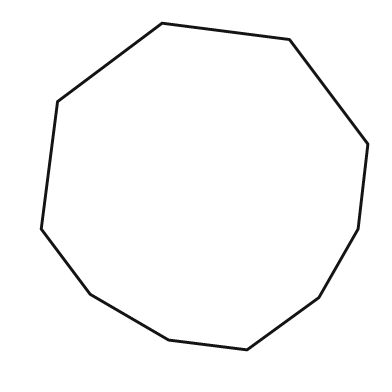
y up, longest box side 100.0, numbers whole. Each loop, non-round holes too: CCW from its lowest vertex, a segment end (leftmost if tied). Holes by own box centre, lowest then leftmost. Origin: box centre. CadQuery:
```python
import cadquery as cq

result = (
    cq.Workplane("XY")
    .moveTo(13.0, -50.0)
    .lineTo(35.0, -34.0)
    .lineTo(47.0, -13.0)
    .lineTo(50.0, 13.0)
    .lineTo(26.0, 45.0)
    .lineTo(-13.0, 50.0)
    .lineTo(-45.0, 26.0)
    .lineTo(-50.0, -13.0)
    .lineTo(-35.0, -33.0)
    .lineTo(-11.0, -47.0)
    .close()
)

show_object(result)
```